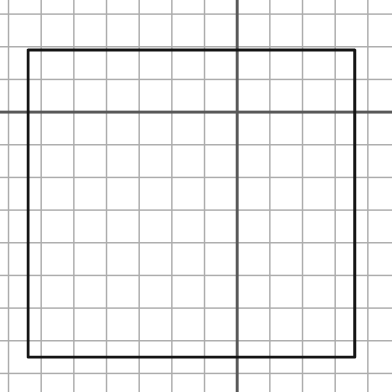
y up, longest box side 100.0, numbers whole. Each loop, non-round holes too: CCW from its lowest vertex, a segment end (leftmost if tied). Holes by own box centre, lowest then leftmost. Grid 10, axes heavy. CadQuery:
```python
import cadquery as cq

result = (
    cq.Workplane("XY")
    .moveTo(-64.0, -75.0)
    .lineTo(36.0, -75.0)
    .lineTo(36.0, 19.0)
    .lineTo(-64.0, 19.0)
    .close()
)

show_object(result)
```